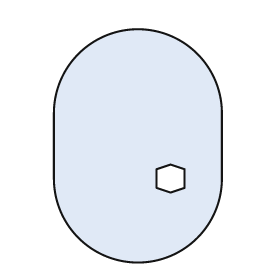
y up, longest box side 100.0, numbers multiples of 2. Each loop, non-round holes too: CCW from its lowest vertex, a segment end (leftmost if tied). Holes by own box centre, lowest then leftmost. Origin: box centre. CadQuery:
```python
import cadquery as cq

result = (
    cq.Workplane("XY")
    .moveTo(-36.0, -14.0)
    .threePointArc((0.0, -50.0), (36.0, -14.0))
    .lineTo(36.0, 14.0)
    .threePointArc((0.0, 50.0), (-36.0, 14.0))
    .close()
    .moveTo(14.0, -20.0)
    .lineTo(20.0, -18.0)
    .lineTo(20.0, -10.0)
    .lineTo(14.0, -8.0)
    .lineTo(8.0, -10.0)
    .lineTo(8.0, -18.0)
    .close()
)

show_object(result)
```